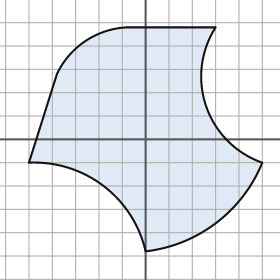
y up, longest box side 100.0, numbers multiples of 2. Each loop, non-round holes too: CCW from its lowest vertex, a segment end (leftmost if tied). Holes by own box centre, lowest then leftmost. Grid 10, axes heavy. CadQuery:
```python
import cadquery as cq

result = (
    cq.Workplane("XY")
    .moveTo(0.0, -48.0)
    .threePointArc((30.0, -36.0), (50.0, -10.0))
    .threePointArc((26.0, 14.0), (30.0, 48.0))
    .lineTo(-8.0, 48.0)
    .threePointArc((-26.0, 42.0), (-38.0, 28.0))
    .lineTo(-50.0, -10.0)
    .threePointArc((-18.0, -20.0), (0.0, -48.0))
    .close()
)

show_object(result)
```